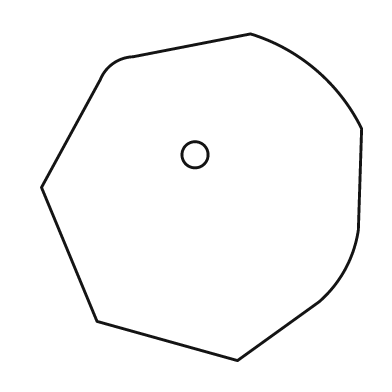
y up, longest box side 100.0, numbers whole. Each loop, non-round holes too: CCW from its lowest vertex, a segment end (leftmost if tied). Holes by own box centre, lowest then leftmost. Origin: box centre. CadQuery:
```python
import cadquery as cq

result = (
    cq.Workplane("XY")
    .moveTo(11.0, -50.0)
    .lineTo(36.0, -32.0)
    .threePointArc((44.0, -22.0), (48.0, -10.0))
    .lineTo(49.0, 21.0)
    .threePointArc((35.0, 39.0), (15.0, 50.0))
    .lineTo(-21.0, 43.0)
    .threePointArc((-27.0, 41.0), (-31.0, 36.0))
    .lineTo(-49.0, 3.0)
    .lineTo(-32.0, -38.0)
    .close()
    .moveTo(-2.0, 13.0)
    .circle(4.0)
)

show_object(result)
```